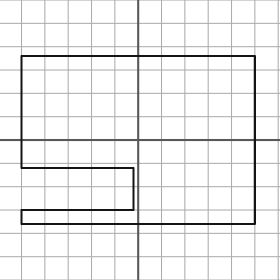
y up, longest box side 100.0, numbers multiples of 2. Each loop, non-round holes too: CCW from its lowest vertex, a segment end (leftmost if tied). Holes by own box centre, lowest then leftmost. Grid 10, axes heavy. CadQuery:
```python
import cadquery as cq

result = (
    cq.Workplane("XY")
    .moveTo(-50.0, -36.0)
    .lineTo(50.0, -36.0)
    .lineTo(50.0, 36.0)
    .lineTo(-50.0, 36.0)
    .lineTo(-50.0, -12.0)
    .lineTo(-2.0, -12.0)
    .lineTo(-2.0, -30.0)
    .lineTo(-50.0, -30.0)
    .close()
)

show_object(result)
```